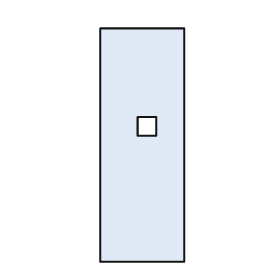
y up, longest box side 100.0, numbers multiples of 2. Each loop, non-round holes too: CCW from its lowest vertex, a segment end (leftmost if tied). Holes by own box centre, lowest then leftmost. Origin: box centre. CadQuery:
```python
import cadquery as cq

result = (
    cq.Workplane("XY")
    .moveTo(-18.0, -50.0)
    .lineTo(18.0, -50.0)
    .lineTo(18.0, 50.0)
    .lineTo(-18.0, 50.0)
    .close()
    .moveTo(-2.0, 4.0)
    .lineTo(6.0, 4.0)
    .lineTo(6.0, 12.0)
    .lineTo(-2.0, 12.0)
    .close()
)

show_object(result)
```